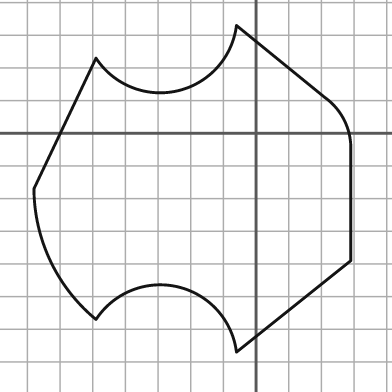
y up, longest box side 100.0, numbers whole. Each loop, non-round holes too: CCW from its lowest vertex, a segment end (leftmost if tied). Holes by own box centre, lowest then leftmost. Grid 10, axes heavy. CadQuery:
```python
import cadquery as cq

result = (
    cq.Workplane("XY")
    .moveTo(-6.0, -67.0)
    .lineTo(29.0, -39.0)
    .lineTo(29.0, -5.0)
    .threePointArc((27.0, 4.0), (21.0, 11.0))
    .lineTo(-6.0, 33.0)
    .threePointArc((-24.0, 13.0), (-49.0, 23.0))
    .lineTo(-68.0, -17.0)
    .threePointArc((-63.0, -39.0), (-49.0, -57.0))
    .threePointArc((-24.0, -47.0), (-6.0, -67.0))
    .close()
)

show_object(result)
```